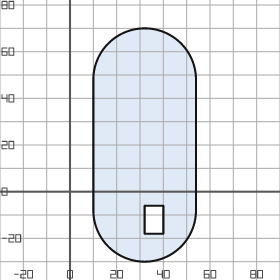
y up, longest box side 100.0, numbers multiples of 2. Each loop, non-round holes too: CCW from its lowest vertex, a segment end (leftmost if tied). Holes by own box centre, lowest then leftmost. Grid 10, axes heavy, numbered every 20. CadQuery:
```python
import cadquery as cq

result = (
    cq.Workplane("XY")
    .moveTo(10.0, -8.0)
    .threePointArc((32.0, -30.0), (54.0, -8.0))
    .lineTo(54.0, 48.0)
    .threePointArc((32.0, 70.0), (10.0, 48.0))
    .close()
    .moveTo(32.0, -18.0)
    .lineTo(40.0, -18.0)
    .lineTo(40.0, -6.0)
    .lineTo(32.0, -6.0)
    .close()
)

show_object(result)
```